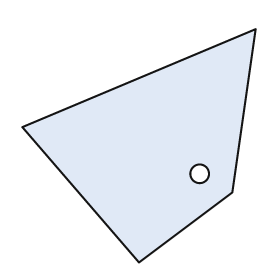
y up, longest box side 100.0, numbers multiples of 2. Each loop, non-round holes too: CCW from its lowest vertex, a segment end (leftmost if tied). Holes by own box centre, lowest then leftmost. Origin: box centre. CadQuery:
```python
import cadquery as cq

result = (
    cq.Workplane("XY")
    .moveTo(0.0, -50.0)
    .lineTo(40.0, -20.0)
    .lineTo(50.0, 50.0)
    .lineTo(-50.0, 8.0)
    .close()
    .moveTo(26.0, -12.0)
    .circle(4.0)
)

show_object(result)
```